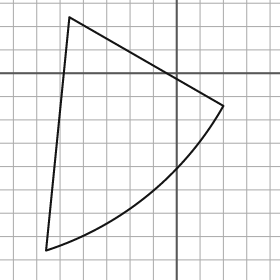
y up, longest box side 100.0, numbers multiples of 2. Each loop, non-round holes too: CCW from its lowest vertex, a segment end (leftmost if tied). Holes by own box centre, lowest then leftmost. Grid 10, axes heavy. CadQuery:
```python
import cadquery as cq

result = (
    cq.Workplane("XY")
    .moveTo(-56.0, -76.0)
    .threePointArc((-12.0, -52.0), (20.0, -14.0))
    .lineTo(-46.0, 24.0)
    .close()
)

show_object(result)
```